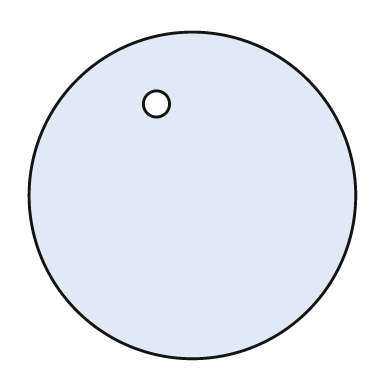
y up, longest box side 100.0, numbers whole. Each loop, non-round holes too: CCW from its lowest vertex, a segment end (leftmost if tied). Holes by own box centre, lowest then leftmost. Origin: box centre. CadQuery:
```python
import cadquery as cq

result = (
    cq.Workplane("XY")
    .moveTo(0.0, 0.0)
    .circle(50.0)
    .moveTo(-11.0, 28.0)
    .circle(4.0)
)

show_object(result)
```